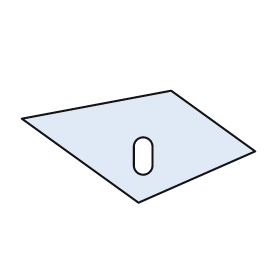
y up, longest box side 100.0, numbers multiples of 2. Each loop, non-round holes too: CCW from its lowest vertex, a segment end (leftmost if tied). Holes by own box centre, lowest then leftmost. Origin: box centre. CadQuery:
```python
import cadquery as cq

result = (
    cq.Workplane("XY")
    .moveTo(0.0, -24.0)
    .lineTo(50.0, -2.0)
    .lineTo(14.0, 24.0)
    .lineTo(-50.0, 12.0)
    .close()
    .moveTo(-2.0, -8.0)
    .threePointArc((2.0, -12.0), (6.0, -8.0))
    .lineTo(6.0, 0.0)
    .threePointArc((2.0, 4.0), (-2.0, 0.0))
    .close()
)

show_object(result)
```